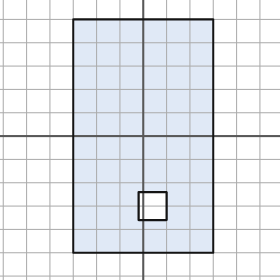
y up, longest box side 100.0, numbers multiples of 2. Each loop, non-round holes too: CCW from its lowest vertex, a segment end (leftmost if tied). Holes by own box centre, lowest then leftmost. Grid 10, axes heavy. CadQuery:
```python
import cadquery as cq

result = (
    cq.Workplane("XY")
    .moveTo(-30.0, -50.0)
    .lineTo(30.0, -50.0)
    .lineTo(30.0, 50.0)
    .lineTo(-30.0, 50.0)
    .close()
    .moveTo(-2.0, -36.0)
    .lineTo(10.0, -36.0)
    .lineTo(10.0, -24.0)
    .lineTo(-2.0, -24.0)
    .close()
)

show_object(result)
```